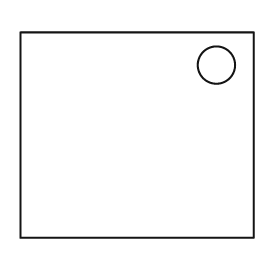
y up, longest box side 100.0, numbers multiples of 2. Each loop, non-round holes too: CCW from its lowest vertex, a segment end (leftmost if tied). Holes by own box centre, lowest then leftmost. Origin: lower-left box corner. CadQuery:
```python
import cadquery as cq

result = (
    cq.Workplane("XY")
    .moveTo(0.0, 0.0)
    .lineTo(100.0, 0.0)
    .lineTo(100.0, 88.0)
    .lineTo(0.0, 88.0)
    .close()
    .moveTo(84.0, 74.0)
    .circle(8.0)
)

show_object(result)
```